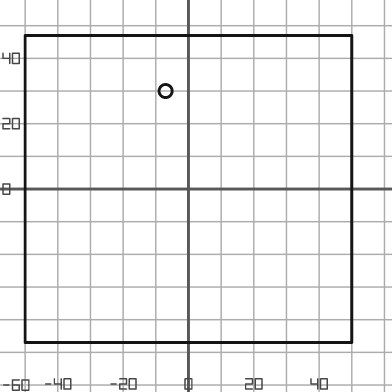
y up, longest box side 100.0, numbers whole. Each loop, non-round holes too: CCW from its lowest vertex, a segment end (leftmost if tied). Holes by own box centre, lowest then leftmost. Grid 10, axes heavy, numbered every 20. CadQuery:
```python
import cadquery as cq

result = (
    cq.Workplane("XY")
    .moveTo(-50.0, -47.0)
    .lineTo(50.0, -47.0)
    .lineTo(50.0, 47.0)
    .lineTo(-50.0, 47.0)
    .close()
    .moveTo(-7.0, 30.0)
    .circle(2.0)
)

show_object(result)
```